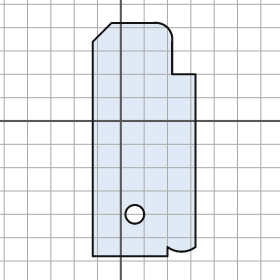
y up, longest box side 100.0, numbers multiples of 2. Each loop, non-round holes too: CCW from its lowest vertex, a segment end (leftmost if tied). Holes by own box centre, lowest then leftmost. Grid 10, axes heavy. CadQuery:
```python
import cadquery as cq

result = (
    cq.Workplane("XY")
    .moveTo(-12.0, -58.0)
    .lineTo(20.0, -58.0)
    .lineTo(20.0, -54.0)
    .threePointArc((26.0, -56.0), (32.0, -54.0))
    .lineTo(32.0, 20.0)
    .lineTo(22.0, 20.0)
    .lineTo(22.0, 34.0)
    .threePointArc((20.0, 40.0), (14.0, 42.0))
    .lineTo(-4.0, 42.0)
    .lineTo(-12.0, 34.0)
    .close()
    .moveTo(6.0, -40.0)
    .circle(4.0)
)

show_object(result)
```